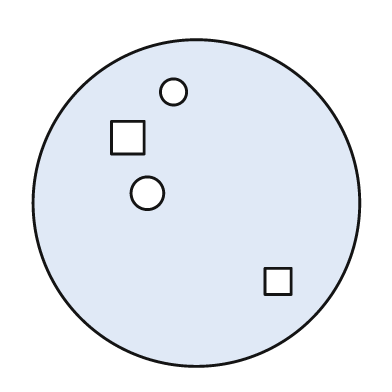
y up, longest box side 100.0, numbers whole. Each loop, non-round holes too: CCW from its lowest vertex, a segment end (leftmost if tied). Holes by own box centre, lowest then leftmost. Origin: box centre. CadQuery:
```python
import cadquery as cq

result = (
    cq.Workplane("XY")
    .moveTo(0.0, 0.0)
    .circle(50.0)
    .moveTo(21.0, -28.0)
    .lineTo(29.0, -28.0)
    .lineTo(29.0, -20.0)
    .lineTo(21.0, -20.0)
    .close()
    .moveTo(-15.0, 3.0)
    .circle(5.0)
    .moveTo(-26.0, 15.0)
    .lineTo(-16.0, 15.0)
    .lineTo(-16.0, 25.0)
    .lineTo(-26.0, 25.0)
    .close()
    .moveTo(-7.0, 34.0)
    .circle(4.0)
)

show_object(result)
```